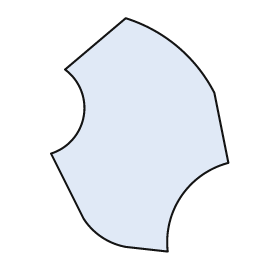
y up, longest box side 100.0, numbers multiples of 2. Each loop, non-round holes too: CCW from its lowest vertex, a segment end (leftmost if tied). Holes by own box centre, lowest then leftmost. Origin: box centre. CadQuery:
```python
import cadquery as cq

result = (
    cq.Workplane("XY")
    .moveTo(12.0, -50.0)
    .threePointArc((18.0, -26.0), (38.0, -12.0))
    .lineTo(32.0, 18.0)
    .threePointArc((16.0, 38.0), (-6.0, 50.0))
    .lineTo(-32.0, 28.0)
    .threePointArc((-24.0, 8.0), (-38.0, -8.0))
    .lineTo(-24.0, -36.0)
    .threePointArc((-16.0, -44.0), (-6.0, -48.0))
    .close()
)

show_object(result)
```